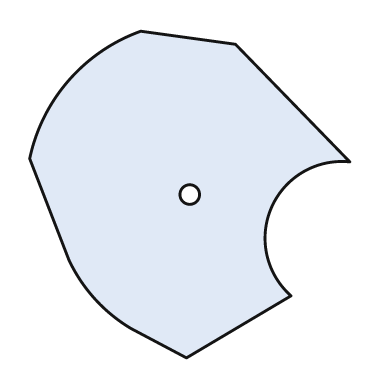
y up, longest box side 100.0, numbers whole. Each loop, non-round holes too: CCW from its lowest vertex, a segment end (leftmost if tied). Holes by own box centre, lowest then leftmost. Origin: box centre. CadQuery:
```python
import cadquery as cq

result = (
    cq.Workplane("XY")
    .moveTo(-1.0, -50.0)
    .lineTo(31.0, -31.0)
    .threePointArc((25.0, -4.0), (49.0, 10.0))
    .lineTo(14.0, 46.0)
    .lineTo(-15.0, 50.0)
    .threePointArc((-37.0, 35.0), (-49.0, 11.0))
    .lineTo(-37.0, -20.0)
    .threePointArc((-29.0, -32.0), (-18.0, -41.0))
    .close()
    .moveTo(0.0, 0.0)
    .circle(3.0)
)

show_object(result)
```